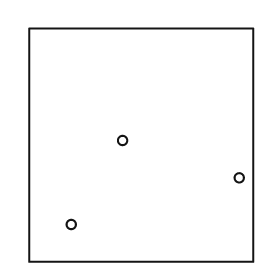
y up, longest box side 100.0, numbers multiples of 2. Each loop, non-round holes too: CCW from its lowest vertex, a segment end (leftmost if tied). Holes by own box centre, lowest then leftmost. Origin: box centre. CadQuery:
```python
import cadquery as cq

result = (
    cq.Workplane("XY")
    .moveTo(-48.0, -50.0)
    .lineTo(48.0, -50.0)
    .lineTo(48.0, 50.0)
    .lineTo(-48.0, 50.0)
    .close()
    .moveTo(-30.0, -34.0)
    .circle(2.0)
    .moveTo(42.0, -14.0)
    .circle(2.0)
    .moveTo(-8.0, 2.0)
    .circle(2.0)
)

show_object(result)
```